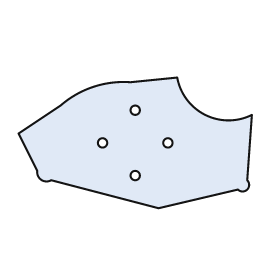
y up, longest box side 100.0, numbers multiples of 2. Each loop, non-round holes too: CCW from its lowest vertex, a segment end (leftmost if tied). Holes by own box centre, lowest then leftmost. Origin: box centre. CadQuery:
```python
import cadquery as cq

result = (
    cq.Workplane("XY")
    .moveTo(10.0, -28.0)
    .lineTo(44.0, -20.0)
    .threePointArc((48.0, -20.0), (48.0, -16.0))
    .lineTo(50.0, 12.0)
    .threePointArc((30.0, 12.0), (18.0, 28.0))
    .lineTo(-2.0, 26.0)
    .threePointArc((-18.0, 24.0), (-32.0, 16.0))
    .lineTo(-50.0, 4.0)
    .lineTo(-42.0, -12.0)
    .threePointArc((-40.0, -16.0), (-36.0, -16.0))
    .close()
    .moveTo(0.0, -14.0)
    .circle(2.0)
    .moveTo(-14.0, 0.0)
    .circle(2.0)
    .moveTo(14.0, 0.0)
    .circle(2.0)
    .moveTo(0.0, 14.0)
    .circle(2.0)
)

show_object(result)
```